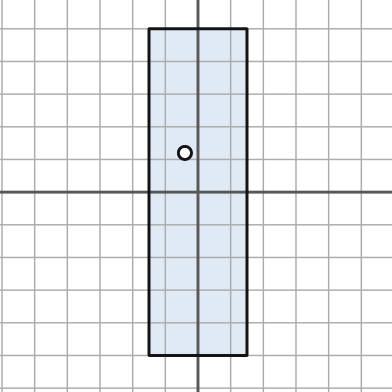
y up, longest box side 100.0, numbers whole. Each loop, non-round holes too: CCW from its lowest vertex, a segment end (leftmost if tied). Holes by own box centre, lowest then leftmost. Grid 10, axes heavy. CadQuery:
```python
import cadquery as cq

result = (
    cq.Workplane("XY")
    .moveTo(-15.0, -50.0)
    .lineTo(15.0, -50.0)
    .lineTo(15.0, 50.0)
    .lineTo(-15.0, 50.0)
    .close()
    .moveTo(-4.0, 12.0)
    .circle(2.0)
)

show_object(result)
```